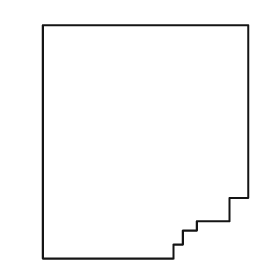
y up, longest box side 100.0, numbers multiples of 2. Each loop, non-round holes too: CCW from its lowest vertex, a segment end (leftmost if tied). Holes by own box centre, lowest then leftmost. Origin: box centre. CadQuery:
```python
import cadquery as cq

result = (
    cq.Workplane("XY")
    .moveTo(-44.0, -50.0)
    .lineTo(12.0, -50.0)
    .lineTo(12.0, -44.0)
    .lineTo(16.0, -44.0)
    .lineTo(16.0, -38.0)
    .lineTo(22.0, -38.0)
    .lineTo(22.0, -34.0)
    .lineTo(36.0, -34.0)
    .lineTo(36.0, -24.0)
    .lineTo(44.0, -24.0)
    .lineTo(44.0, 50.0)
    .lineTo(-44.0, 50.0)
    .close()
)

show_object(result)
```